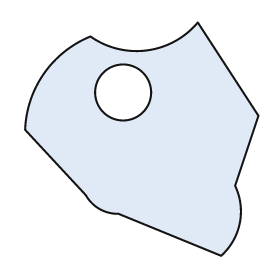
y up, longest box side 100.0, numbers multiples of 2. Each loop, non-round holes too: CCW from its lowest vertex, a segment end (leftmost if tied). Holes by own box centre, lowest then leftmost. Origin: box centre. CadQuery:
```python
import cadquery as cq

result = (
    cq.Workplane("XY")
    .moveTo(34.0, -50.0)
    .threePointArc((42.0, -36.0), (40.0, -20.0))
    .lineTo(50.0, 10.0)
    .lineTo(24.0, 50.0)
    .threePointArc((2.0, 38.0), (-22.0, 44.0))
    .threePointArc((-42.0, 28.0), (-50.0, 4.0))
    .lineTo(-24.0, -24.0)
    .threePointArc((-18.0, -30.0), (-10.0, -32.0))
    .close()
    .moveTo(-8.0, 20.0)
    .circle(12.0)
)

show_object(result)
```